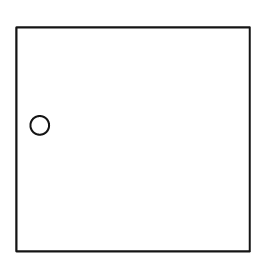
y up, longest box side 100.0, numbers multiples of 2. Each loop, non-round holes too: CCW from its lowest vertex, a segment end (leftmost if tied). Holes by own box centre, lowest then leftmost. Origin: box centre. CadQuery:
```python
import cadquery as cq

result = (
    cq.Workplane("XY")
    .moveTo(-50.0, -48.0)
    .lineTo(50.0, -48.0)
    .lineTo(50.0, 48.0)
    .lineTo(-50.0, 48.0)
    .close()
    .moveTo(-40.0, 6.0)
    .circle(4.0)
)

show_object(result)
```